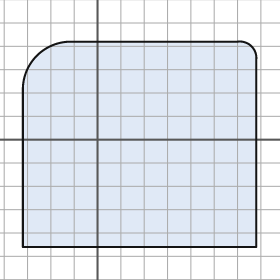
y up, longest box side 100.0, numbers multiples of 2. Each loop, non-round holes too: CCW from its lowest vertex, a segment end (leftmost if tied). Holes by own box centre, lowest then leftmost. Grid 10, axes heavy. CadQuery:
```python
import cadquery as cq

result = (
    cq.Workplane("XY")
    .moveTo(-32.0, -46.0)
    .lineTo(68.0, -46.0)
    .lineTo(68.0, 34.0)
    .threePointArc((66.0, 40.0), (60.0, 42.0))
    .lineTo(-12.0, 42.0)
    .threePointArc((-26.0, 36.0), (-32.0, 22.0))
    .close()
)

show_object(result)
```